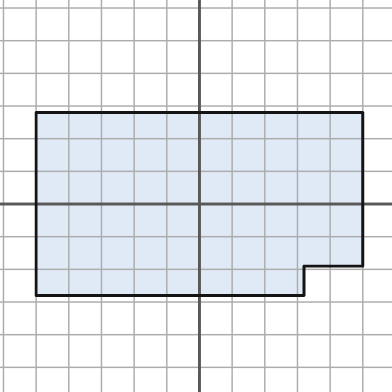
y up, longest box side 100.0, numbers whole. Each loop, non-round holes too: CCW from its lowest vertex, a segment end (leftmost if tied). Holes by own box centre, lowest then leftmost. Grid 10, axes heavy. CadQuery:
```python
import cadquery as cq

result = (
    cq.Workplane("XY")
    .moveTo(-50.0, -28.0)
    .lineTo(32.0, -28.0)
    .lineTo(32.0, -19.0)
    .lineTo(50.0, -19.0)
    .lineTo(50.0, 28.0)
    .lineTo(-50.0, 28.0)
    .close()
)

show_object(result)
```